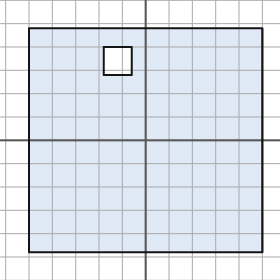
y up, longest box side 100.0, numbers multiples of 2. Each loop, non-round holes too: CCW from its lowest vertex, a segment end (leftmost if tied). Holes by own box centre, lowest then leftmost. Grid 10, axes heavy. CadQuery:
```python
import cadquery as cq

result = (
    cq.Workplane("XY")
    .moveTo(-50.0, -48.0)
    .lineTo(50.0, -48.0)
    .lineTo(50.0, 48.0)
    .lineTo(-50.0, 48.0)
    .close()
    .moveTo(-18.0, 28.0)
    .lineTo(-6.0, 28.0)
    .lineTo(-6.0, 40.0)
    .lineTo(-18.0, 40.0)
    .close()
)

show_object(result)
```